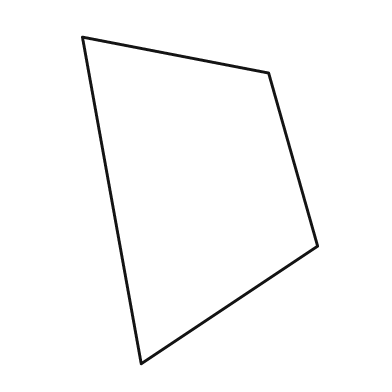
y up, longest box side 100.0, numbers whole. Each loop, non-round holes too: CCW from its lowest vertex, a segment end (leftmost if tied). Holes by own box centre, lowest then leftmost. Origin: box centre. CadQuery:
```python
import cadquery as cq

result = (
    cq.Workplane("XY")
    .moveTo(-18.0, -50.0)
    .lineTo(36.0, -14.0)
    .lineTo(21.0, 39.0)
    .lineTo(-36.0, 50.0)
    .close()
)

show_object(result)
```